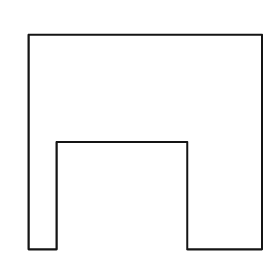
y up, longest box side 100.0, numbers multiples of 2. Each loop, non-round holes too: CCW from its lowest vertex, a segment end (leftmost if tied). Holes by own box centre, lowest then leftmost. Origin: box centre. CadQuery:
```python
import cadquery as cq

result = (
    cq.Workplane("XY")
    .moveTo(-50.0, -46.0)
    .lineTo(-38.0, -46.0)
    .lineTo(-38.0, 0.0)
    .lineTo(18.0, 0.0)
    .lineTo(18.0, -46.0)
    .lineTo(50.0, -46.0)
    .lineTo(50.0, 46.0)
    .lineTo(-50.0, 46.0)
    .close()
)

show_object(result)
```